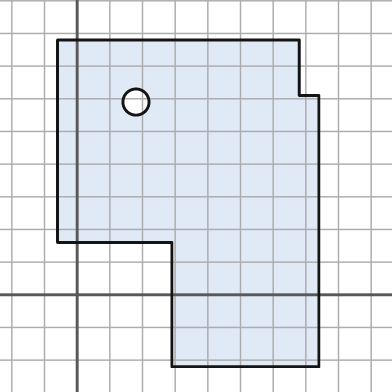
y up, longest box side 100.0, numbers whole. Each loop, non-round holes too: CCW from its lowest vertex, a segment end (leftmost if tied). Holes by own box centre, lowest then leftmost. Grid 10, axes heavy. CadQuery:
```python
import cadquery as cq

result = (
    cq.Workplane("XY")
    .moveTo(29.0, -22.0)
    .lineTo(74.0, -22.0)
    .lineTo(74.0, 61.0)
    .lineTo(68.0, 61.0)
    .lineTo(68.0, 78.0)
    .lineTo(-6.0, 78.0)
    .lineTo(-6.0, 16.0)
    .lineTo(29.0, 16.0)
    .close()
    .moveTo(18.0, 59.0)
    .circle(4.0)
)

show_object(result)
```